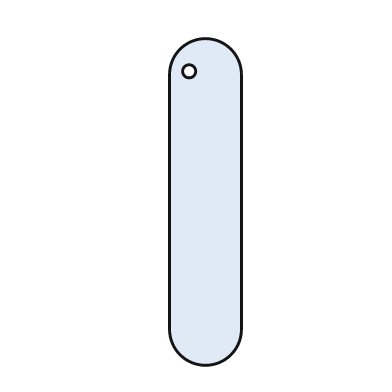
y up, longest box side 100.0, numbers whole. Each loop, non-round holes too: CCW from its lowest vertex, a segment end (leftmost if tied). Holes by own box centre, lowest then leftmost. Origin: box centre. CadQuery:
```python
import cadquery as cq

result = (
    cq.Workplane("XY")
    .moveTo(-11.0, -39.0)
    .threePointArc((0.0, -50.0), (11.0, -39.0))
    .lineTo(11.0, 39.0)
    .threePointArc((0.0, 50.0), (-11.0, 39.0))
    .close()
    .moveTo(-5.0, 40.0)
    .circle(2.0)
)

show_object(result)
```